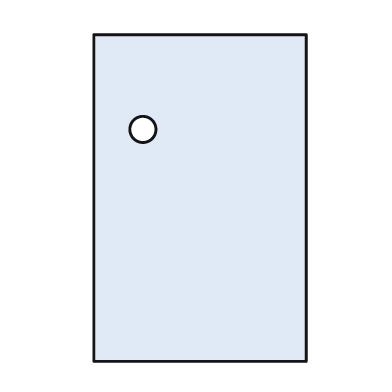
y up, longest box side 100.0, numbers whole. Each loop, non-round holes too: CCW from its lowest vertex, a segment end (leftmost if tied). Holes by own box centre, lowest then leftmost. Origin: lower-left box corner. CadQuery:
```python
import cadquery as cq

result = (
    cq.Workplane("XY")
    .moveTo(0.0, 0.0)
    .lineTo(65.0, 0.0)
    .lineTo(65.0, 100.0)
    .lineTo(0.0, 100.0)
    .close()
    .moveTo(15.0, 71.0)
    .circle(4.0)
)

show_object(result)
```